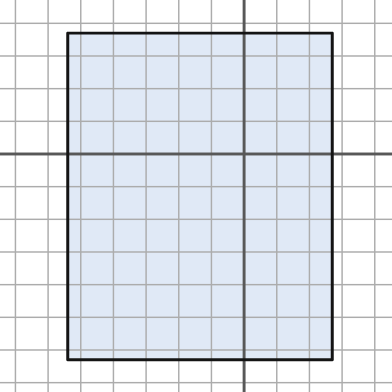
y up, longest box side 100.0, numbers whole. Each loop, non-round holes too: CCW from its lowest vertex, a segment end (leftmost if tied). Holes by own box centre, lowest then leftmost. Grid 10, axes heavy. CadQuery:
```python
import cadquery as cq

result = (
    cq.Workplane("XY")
    .moveTo(-54.0, -63.0)
    .lineTo(27.0, -63.0)
    .lineTo(27.0, 37.0)
    .lineTo(-54.0, 37.0)
    .close()
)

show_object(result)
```